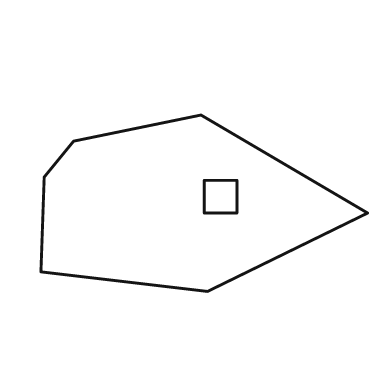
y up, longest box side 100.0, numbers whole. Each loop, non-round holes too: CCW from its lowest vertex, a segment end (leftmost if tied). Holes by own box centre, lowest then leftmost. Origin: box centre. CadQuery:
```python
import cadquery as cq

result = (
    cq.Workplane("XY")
    .moveTo(1.0, -27.0)
    .lineTo(50.0, -3.0)
    .lineTo(-1.0, 27.0)
    .lineTo(-40.0, 19.0)
    .lineTo(-49.0, 8.0)
    .lineTo(-50.0, -21.0)
    .close()
    .moveTo(0.0, -3.0)
    .lineTo(10.0, -3.0)
    .lineTo(10.0, 7.0)
    .lineTo(0.0, 7.0)
    .close()
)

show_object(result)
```